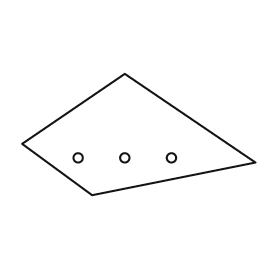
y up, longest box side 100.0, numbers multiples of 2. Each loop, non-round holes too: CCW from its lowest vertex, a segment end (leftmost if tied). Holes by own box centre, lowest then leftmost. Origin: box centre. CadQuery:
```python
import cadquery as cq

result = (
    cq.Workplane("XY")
    .moveTo(-20.0, -26.0)
    .lineTo(50.0, -12.0)
    .lineTo(-6.0, 26.0)
    .lineTo(-50.0, -4.0)
    .close()
    .moveTo(-26.0, -10.0)
    .circle(2.0)
    .moveTo(-6.0, -10.0)
    .circle(2.0)
    .moveTo(14.0, -10.0)
    .circle(2.0)
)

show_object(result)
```